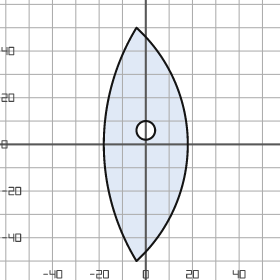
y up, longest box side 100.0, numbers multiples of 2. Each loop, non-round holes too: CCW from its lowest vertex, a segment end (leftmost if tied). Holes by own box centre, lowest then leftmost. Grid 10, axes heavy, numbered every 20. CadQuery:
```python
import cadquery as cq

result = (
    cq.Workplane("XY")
    .moveTo(-4.0, -50.0)
    .threePointArc((18.0, 0.0), (-4.0, 50.0))
    .threePointArc((-18.0, 0.0), (-4.0, -50.0))
    .close()
    .moveTo(0.0, 6.0)
    .circle(4.0)
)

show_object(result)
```